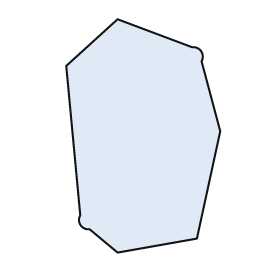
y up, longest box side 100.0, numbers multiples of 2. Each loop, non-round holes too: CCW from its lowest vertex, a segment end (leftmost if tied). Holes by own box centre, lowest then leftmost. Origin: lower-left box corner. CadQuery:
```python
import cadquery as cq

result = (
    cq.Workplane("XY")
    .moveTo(22.0, 0.0)
    .lineTo(56.0, 6.0)
    .lineTo(66.0, 52.0)
    .lineTo(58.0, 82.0)
    .threePointArc((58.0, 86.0), (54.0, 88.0))
    .lineTo(22.0, 100.0)
    .lineTo(0.0, 80.0)
    .lineTo(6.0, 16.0)
    .threePointArc((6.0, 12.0), (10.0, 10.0))
    .close()
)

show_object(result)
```